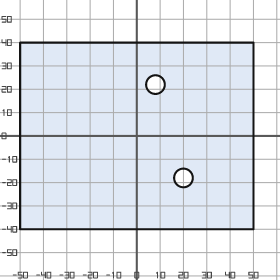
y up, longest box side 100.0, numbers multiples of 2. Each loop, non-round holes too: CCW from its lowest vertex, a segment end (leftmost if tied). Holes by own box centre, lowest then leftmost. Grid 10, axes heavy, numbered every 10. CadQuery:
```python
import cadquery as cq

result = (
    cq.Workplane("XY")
    .moveTo(-50.0, -40.0)
    .lineTo(50.0, -40.0)
    .lineTo(50.0, 40.0)
    .lineTo(-50.0, 40.0)
    .close()
    .moveTo(20.0, -18.0)
    .circle(4.0)
    .moveTo(8.0, 22.0)
    .circle(4.0)
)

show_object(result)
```